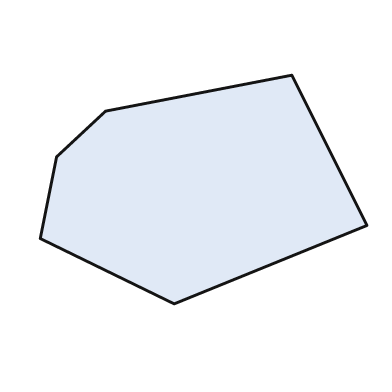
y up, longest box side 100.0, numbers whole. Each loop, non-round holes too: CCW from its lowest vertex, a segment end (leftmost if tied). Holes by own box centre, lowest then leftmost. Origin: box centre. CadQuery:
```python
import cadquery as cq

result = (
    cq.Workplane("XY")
    .moveTo(-9.0, -35.0)
    .lineTo(50.0, -11.0)
    .lineTo(27.0, 35.0)
    .lineTo(-30.0, 24.0)
    .lineTo(-45.0, 10.0)
    .lineTo(-50.0, -15.0)
    .close()
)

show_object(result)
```